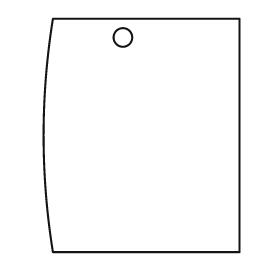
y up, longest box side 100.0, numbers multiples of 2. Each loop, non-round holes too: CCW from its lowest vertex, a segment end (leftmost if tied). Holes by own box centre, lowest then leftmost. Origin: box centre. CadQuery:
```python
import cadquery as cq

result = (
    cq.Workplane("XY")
    .moveTo(-38.0, -50.0)
    .lineTo(42.0, -50.0)
    .lineTo(42.0, 50.0)
    .lineTo(-38.0, 50.0)
    .threePointArc((-42.0, 0.0), (-38.0, -50.0))
    .close()
    .moveTo(-8.0, 42.0)
    .circle(4.0)
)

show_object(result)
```